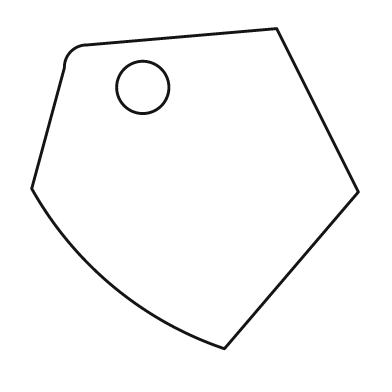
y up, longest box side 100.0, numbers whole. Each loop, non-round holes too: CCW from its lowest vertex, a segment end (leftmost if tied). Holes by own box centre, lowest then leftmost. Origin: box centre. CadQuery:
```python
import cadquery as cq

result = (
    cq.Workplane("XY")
    .moveTo(9.0, -49.0)
    .lineTo(50.0, -1.0)
    .lineTo(25.0, 49.0)
    .lineTo(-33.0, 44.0)
    .threePointArc((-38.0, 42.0), (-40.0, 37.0))
    .lineTo(-50.0, 0.0)
    .threePointArc((-25.0, -30.0), (9.0, -49.0))
    .close()
    .moveTo(-16.0, 31.0)
    .circle(8.0)
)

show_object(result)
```